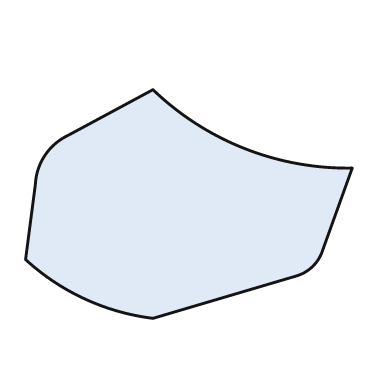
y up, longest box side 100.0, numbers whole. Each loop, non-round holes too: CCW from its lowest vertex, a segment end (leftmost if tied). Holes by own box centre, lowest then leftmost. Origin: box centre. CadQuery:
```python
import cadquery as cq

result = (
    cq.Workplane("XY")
    .moveTo(-11.0, -35.0)
    .lineTo(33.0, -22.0)
    .threePointArc((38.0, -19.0), (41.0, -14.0))
    .lineTo(50.0, 11.0)
    .threePointArc((17.0, 17.0), (-11.0, 35.0))
    .lineTo(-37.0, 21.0)
    .threePointArc((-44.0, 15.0), (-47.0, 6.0))
    .lineTo(-50.0, -17.0)
    .threePointArc((-32.0, -29.0), (-11.0, -35.0))
    .close()
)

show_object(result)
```